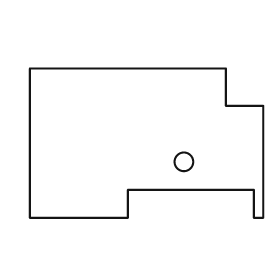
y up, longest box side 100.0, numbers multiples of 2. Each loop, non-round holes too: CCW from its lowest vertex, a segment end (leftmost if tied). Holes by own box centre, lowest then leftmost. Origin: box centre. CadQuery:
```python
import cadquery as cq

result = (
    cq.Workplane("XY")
    .moveTo(-50.0, -32.0)
    .lineTo(-8.0, -32.0)
    .lineTo(-8.0, -20.0)
    .lineTo(46.0, -20.0)
    .lineTo(46.0, -32.0)
    .lineTo(50.0, -32.0)
    .lineTo(50.0, 16.0)
    .lineTo(34.0, 16.0)
    .lineTo(34.0, 32.0)
    .lineTo(-50.0, 32.0)
    .close()
    .moveTo(16.0, -8.0)
    .circle(4.0)
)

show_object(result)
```